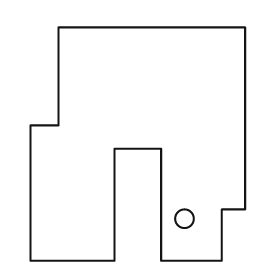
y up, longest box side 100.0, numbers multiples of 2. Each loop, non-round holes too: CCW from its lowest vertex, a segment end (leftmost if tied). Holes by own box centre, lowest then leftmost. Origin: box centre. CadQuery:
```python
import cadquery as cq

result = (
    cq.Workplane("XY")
    .moveTo(-46.0, -50.0)
    .lineTo(-10.0, -50.0)
    .lineTo(-10.0, -2.0)
    .lineTo(10.0, -2.0)
    .lineTo(10.0, -50.0)
    .lineTo(36.0, -50.0)
    .lineTo(36.0, -28.0)
    .lineTo(46.0, -28.0)
    .lineTo(46.0, 50.0)
    .lineTo(-34.0, 50.0)
    .lineTo(-34.0, 8.0)
    .lineTo(-46.0, 8.0)
    .close()
    .moveTo(20.0, -32.0)
    .circle(4.0)
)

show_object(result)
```